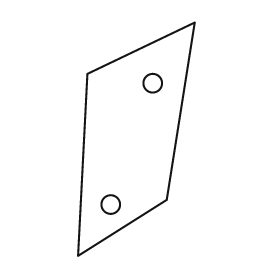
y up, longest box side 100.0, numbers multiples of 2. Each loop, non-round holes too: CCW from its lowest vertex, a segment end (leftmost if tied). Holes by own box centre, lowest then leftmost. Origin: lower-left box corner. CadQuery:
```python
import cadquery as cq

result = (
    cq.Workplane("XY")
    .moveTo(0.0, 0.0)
    .lineTo(38.0, 24.0)
    .lineTo(50.0, 100.0)
    .lineTo(4.0, 78.0)
    .close()
    .moveTo(14.0, 22.0)
    .circle(4.0)
    .moveTo(32.0, 74.0)
    .circle(4.0)
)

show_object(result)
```